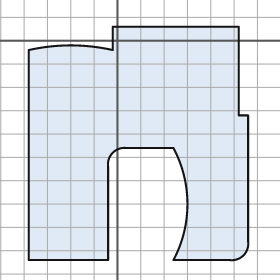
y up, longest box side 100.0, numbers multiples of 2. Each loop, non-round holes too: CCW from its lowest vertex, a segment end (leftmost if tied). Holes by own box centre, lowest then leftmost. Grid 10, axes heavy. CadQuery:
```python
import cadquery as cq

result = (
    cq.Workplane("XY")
    .moveTo(-38.0, -94.0)
    .lineTo(-4.0, -94.0)
    .lineTo(-4.0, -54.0)
    .threePointArc((-2.0, -48.0), (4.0, -46.0))
    .lineTo(24.0, -46.0)
    .threePointArc((30.0, -70.0), (24.0, -94.0))
    .lineTo(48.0, -94.0)
    .threePointArc((54.0, -92.0), (56.0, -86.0))
    .lineTo(56.0, -32.0)
    .lineTo(52.0, -32.0)
    .lineTo(52.0, 6.0)
    .lineTo(-2.0, 6.0)
    .lineTo(-2.0, -4.0)
    .threePointArc((-20.0, -2.0), (-38.0, -4.0))
    .close()
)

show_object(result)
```